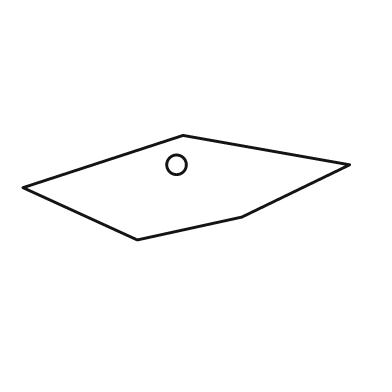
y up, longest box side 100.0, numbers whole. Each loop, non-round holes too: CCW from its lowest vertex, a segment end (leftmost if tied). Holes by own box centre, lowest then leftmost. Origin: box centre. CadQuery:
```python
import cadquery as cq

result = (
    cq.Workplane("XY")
    .moveTo(-15.0, -16.0)
    .lineTo(17.0, -9.0)
    .lineTo(50.0, 7.0)
    .lineTo(-1.0, 16.0)
    .lineTo(-50.0, 0.0)
    .close()
    .moveTo(-3.0, 7.0)
    .circle(3.0)
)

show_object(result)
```